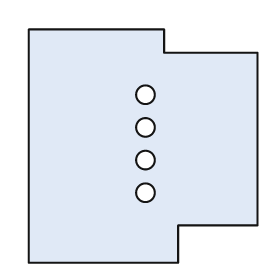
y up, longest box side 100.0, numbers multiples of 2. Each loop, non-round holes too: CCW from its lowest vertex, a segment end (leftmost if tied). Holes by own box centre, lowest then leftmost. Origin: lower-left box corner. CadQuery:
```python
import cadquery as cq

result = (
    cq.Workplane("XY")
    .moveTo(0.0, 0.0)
    .lineTo(64.0, 0.0)
    .lineTo(64.0, 16.0)
    .lineTo(98.0, 16.0)
    .lineTo(98.0, 90.0)
    .lineTo(58.0, 90.0)
    .lineTo(58.0, 100.0)
    .lineTo(0.0, 100.0)
    .close()
    .moveTo(50.0, 30.0)
    .circle(4.0)
    .moveTo(50.0, 44.0)
    .circle(4.0)
    .moveTo(50.0, 58.0)
    .circle(4.0)
    .moveTo(50.0, 72.0)
    .circle(4.0)
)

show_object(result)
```